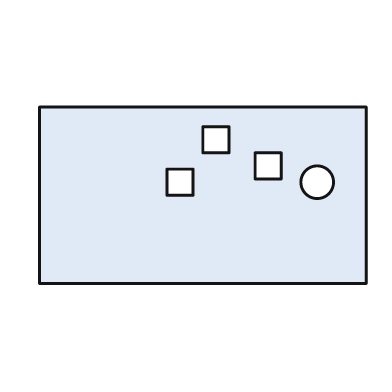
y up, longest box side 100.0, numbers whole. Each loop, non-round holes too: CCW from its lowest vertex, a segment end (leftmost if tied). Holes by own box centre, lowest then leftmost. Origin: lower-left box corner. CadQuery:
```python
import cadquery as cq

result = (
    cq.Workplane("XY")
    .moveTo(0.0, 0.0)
    .lineTo(100.0, 0.0)
    .lineTo(100.0, 54.0)
    .lineTo(0.0, 54.0)
    .close()
    .moveTo(39.0, 27.0)
    .lineTo(47.0, 27.0)
    .lineTo(47.0, 35.0)
    .lineTo(39.0, 35.0)
    .close()
    .moveTo(85.0, 31.0)
    .circle(5.0)
    .moveTo(66.0, 32.0)
    .lineTo(74.0, 32.0)
    .lineTo(74.0, 40.0)
    .lineTo(66.0, 40.0)
    .close()
    .moveTo(50.0, 40.0)
    .lineTo(58.0, 40.0)
    .lineTo(58.0, 48.0)
    .lineTo(50.0, 48.0)
    .close()
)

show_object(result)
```